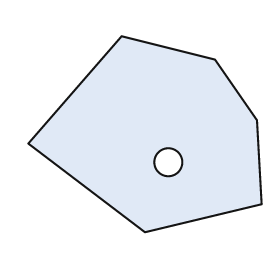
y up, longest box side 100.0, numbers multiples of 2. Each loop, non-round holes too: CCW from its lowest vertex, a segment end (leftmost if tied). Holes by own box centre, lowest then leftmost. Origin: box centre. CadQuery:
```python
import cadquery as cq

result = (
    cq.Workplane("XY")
    .moveTo(0.0, -42.0)
    .lineTo(50.0, -30.0)
    .lineTo(48.0, 6.0)
    .lineTo(30.0, 32.0)
    .lineTo(-10.0, 42.0)
    .lineTo(-50.0, -4.0)
    .close()
    .moveTo(10.0, -12.0)
    .circle(6.0)
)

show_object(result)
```